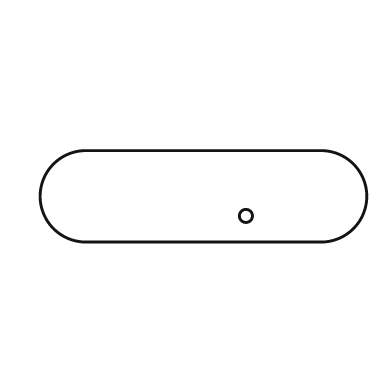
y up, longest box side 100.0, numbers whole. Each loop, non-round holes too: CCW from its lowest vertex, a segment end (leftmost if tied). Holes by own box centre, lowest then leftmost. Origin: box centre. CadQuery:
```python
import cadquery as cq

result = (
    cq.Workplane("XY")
    .moveTo(-36.0, -14.0)
    .lineTo(36.0, -14.0)
    .threePointArc((50.0, 0.0), (36.0, 14.0))
    .lineTo(-36.0, 14.0)
    .threePointArc((-50.0, 0.0), (-36.0, -14.0))
    .close()
    .moveTo(13.0, -6.0)
    .circle(2.0)
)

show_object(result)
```